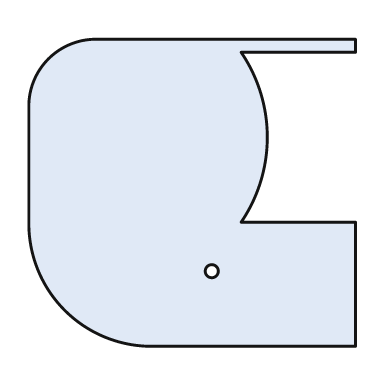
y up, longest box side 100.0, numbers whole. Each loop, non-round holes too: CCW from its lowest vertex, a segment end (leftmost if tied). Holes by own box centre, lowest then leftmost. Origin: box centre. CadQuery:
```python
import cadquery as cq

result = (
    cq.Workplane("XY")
    .moveTo(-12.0, -47.0)
    .lineTo(50.0, -47.0)
    .lineTo(50.0, -9.0)
    .lineTo(15.0, -9.0)
    .threePointArc((23.0, 17.0), (15.0, 43.0))
    .lineTo(50.0, 43.0)
    .lineTo(50.0, 47.0)
    .lineTo(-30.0, 47.0)
    .threePointArc((-44.0, 41.0), (-50.0, 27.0))
    .lineTo(-50.0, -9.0)
    .threePointArc((-39.0, -36.0), (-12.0, -47.0))
    .close()
    .moveTo(6.0, -24.0)
    .circle(2.0)
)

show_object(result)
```